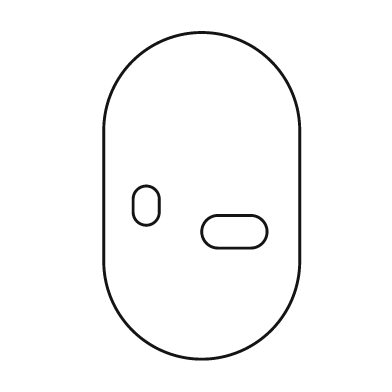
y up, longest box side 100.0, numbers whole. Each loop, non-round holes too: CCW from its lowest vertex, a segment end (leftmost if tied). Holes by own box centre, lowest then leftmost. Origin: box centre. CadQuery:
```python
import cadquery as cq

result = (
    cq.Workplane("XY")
    .moveTo(-30.0, -20.0)
    .threePointArc((0.0, -50.0), (30.0, -20.0))
    .lineTo(30.0, 20.0)
    .threePointArc((0.0, 50.0), (-30.0, 20.0))
    .close()
    .moveTo(5.0, -16.0)
    .lineTo(15.0, -16.0)
    .threePointArc((20.0, -11.0), (15.0, -6.0))
    .lineTo(5.0, -6.0)
    .threePointArc((0.0, -11.0), (5.0, -16.0))
    .close()
    .moveTo(-21.0, -5.0)
    .threePointArc((-17.0, -9.0), (-13.0, -5.0))
    .lineTo(-13.0, -1.0)
    .threePointArc((-17.0, 3.0), (-21.0, -1.0))
    .close()
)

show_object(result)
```